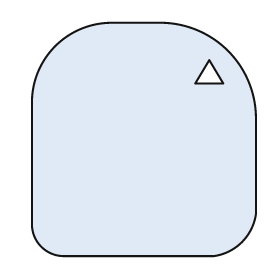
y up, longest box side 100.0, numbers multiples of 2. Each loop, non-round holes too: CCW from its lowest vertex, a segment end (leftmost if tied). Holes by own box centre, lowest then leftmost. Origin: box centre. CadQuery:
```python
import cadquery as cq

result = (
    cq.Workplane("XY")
    .moveTo(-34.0, -50.0)
    .lineTo(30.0, -50.0)
    .threePointArc((42.0, -44.0), (48.0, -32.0))
    .lineTo(48.0, 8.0)
    .threePointArc((36.0, 38.0), (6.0, 50.0))
    .lineTo(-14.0, 50.0)
    .threePointArc((-38.0, 40.0), (-48.0, 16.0))
    .lineTo(-48.0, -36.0)
    .threePointArc((-44.0, -46.0), (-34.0, -50.0))
    .close()
    .moveTo(22.0, 24.0)
    .lineTo(34.0, 24.0)
    .lineTo(28.0, 34.0)
    .close()
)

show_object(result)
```